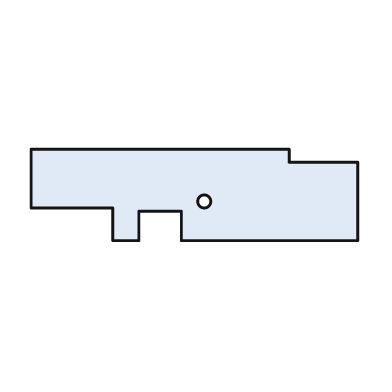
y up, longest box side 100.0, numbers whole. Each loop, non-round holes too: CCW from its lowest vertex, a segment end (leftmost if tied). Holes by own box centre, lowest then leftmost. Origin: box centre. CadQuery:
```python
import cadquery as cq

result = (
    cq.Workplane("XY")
    .moveTo(-25.0, -14.0)
    .lineTo(-17.0, -14.0)
    .lineTo(-17.0, -5.0)
    .lineTo(-4.0, -5.0)
    .lineTo(-4.0, -14.0)
    .lineTo(50.0, -14.0)
    .lineTo(50.0, 10.0)
    .lineTo(29.0, 10.0)
    .lineTo(29.0, 14.0)
    .lineTo(-50.0, 14.0)
    .lineTo(-50.0, -4.0)
    .lineTo(-25.0, -4.0)
    .close()
    .moveTo(3.0, -2.0)
    .circle(2.0)
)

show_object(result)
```